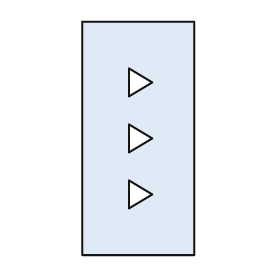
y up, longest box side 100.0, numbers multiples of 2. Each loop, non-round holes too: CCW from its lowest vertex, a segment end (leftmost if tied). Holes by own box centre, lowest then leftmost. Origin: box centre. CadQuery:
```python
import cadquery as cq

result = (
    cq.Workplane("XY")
    .moveTo(-24.0, -50.0)
    .lineTo(24.0, -50.0)
    .lineTo(24.0, 50.0)
    .lineTo(-24.0, 50.0)
    .close()
    .moveTo(-4.0, -30.0)
    .lineTo(6.0, -24.0)
    .lineTo(-4.0, -18.0)
    .close()
    .moveTo(-4.0, -6.0)
    .lineTo(6.0, 0.0)
    .lineTo(-4.0, 6.0)
    .close()
    .moveTo(-4.0, 18.0)
    .lineTo(6.0, 24.0)
    .lineTo(-4.0, 30.0)
    .close()
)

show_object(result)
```